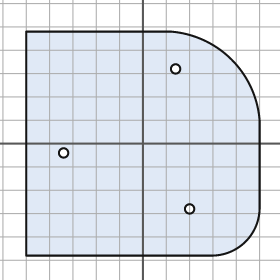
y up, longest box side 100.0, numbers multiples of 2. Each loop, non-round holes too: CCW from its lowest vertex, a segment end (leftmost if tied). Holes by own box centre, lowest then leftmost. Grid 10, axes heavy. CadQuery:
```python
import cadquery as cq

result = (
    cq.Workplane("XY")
    .moveTo(-50.0, -48.0)
    .lineTo(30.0, -48.0)
    .threePointArc((44.0, -42.0), (50.0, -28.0))
    .lineTo(50.0, 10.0)
    .threePointArc((38.0, 36.0), (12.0, 48.0))
    .lineTo(-50.0, 48.0)
    .close()
    .moveTo(20.0, -28.0)
    .circle(2.0)
    .moveTo(-34.0, -4.0)
    .circle(2.0)
    .moveTo(14.0, 32.0)
    .circle(2.0)
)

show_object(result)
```